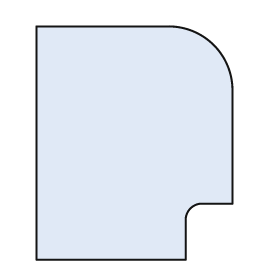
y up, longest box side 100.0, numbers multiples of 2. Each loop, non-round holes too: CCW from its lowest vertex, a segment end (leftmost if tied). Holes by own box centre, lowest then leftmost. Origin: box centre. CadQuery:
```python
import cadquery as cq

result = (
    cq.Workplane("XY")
    .moveTo(-42.0, -50.0)
    .lineTo(22.0, -50.0)
    .lineTo(22.0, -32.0)
    .threePointArc((24.0, -28.0), (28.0, -26.0))
    .lineTo(42.0, -26.0)
    .lineTo(42.0, 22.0)
    .threePointArc((34.0, 42.0), (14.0, 50.0))
    .lineTo(-42.0, 50.0)
    .close()
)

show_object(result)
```